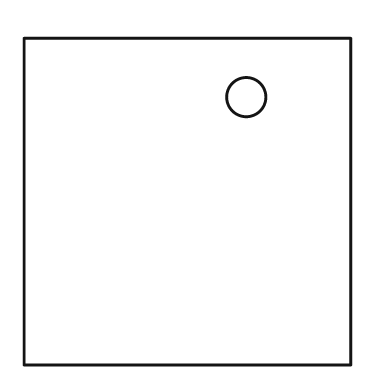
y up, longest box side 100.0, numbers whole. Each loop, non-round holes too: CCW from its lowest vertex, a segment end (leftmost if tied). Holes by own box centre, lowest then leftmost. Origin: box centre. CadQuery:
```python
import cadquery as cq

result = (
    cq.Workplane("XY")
    .moveTo(-50.0, -50.0)
    .lineTo(50.0, -50.0)
    .lineTo(50.0, 50.0)
    .lineTo(-50.0, 50.0)
    .close()
    .moveTo(18.0, 32.0)
    .circle(6.0)
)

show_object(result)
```